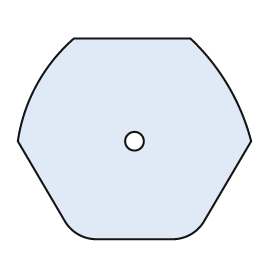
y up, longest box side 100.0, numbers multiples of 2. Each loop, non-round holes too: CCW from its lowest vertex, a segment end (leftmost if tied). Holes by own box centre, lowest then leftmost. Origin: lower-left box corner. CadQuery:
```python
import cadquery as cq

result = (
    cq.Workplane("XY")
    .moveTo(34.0, 0.0)
    .lineTo(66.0, 0.0)
    .threePointArc((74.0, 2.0), (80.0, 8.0))
    .lineTo(100.0, 42.0)
    .threePointArc((90.0, 66.0), (74.0, 86.0))
    .lineTo(24.0, 86.0)
    .threePointArc((8.0, 66.0), (0.0, 42.0))
    .lineTo(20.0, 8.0)
    .threePointArc((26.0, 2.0), (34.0, 0.0))
    .close()
    .moveTo(50.0, 42.0)
    .circle(4.0)
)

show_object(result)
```